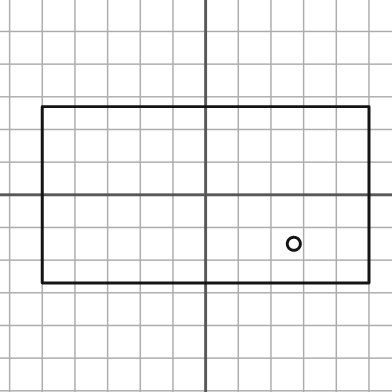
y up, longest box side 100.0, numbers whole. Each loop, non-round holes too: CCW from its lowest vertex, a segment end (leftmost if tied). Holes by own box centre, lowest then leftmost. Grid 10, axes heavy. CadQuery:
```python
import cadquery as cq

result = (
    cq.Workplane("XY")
    .moveTo(-50.0, -27.0)
    .lineTo(50.0, -27.0)
    .lineTo(50.0, 27.0)
    .lineTo(-50.0, 27.0)
    .close()
    .moveTo(27.0, -15.0)
    .circle(2.0)
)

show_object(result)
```